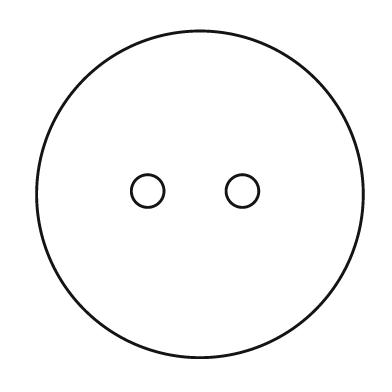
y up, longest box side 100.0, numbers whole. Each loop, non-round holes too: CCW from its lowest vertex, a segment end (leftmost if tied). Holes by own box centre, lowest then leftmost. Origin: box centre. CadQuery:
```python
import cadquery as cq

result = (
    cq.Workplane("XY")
    .moveTo(0.0, 0.0)
    .circle(50.0)
    .moveTo(-16.0, 1.0)
    .circle(5.0)
    .moveTo(13.0, 1.0)
    .circle(5.0)
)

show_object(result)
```